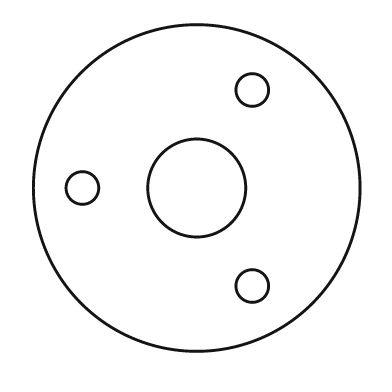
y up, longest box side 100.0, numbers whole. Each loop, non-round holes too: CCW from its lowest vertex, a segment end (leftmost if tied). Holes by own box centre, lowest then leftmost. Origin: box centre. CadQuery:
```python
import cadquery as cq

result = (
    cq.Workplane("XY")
    .moveTo(0.0, 0.0)
    .circle(50.0)
    .moveTo(17.0, -30.0)
    .circle(5.0)
    .moveTo(-35.0, 0.0)
    .circle(5.0)
    .moveTo(0.0, 0.0)
    .circle(15.0)
    .moveTo(17.0, 30.0)
    .circle(5.0)
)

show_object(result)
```